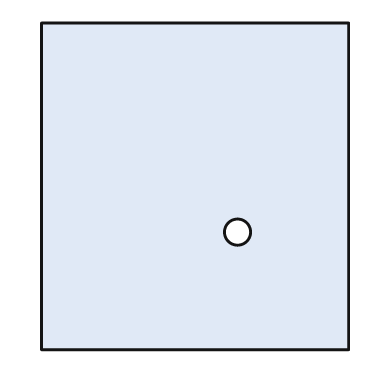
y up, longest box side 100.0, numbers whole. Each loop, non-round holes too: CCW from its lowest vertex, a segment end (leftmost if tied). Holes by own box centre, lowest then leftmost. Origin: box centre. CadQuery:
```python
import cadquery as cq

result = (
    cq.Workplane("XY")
    .moveTo(-47.0, -50.0)
    .lineTo(47.0, -50.0)
    .lineTo(47.0, 50.0)
    .lineTo(-47.0, 50.0)
    .close()
    .moveTo(13.0, -14.0)
    .circle(4.0)
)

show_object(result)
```